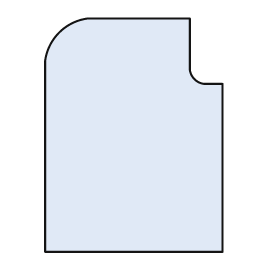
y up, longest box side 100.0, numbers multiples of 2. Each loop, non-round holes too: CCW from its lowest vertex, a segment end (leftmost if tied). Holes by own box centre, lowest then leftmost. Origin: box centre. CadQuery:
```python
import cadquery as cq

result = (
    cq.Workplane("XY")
    .moveTo(-38.0, -50.0)
    .lineTo(38.0, -50.0)
    .lineTo(38.0, 22.0)
    .lineTo(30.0, 22.0)
    .threePointArc((26.0, 24.0), (24.0, 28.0))
    .lineTo(24.0, 50.0)
    .lineTo(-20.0, 50.0)
    .threePointArc((-32.0, 44.0), (-38.0, 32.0))
    .close()
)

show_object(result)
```